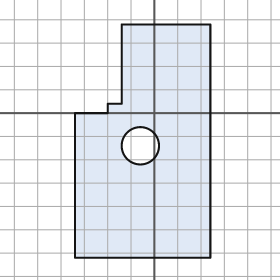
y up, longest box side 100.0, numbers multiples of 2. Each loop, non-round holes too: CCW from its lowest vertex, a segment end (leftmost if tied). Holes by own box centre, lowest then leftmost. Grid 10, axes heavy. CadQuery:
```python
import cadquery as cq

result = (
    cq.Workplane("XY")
    .moveTo(-34.0, -62.0)
    .lineTo(24.0, -62.0)
    .lineTo(24.0, 38.0)
    .lineTo(-14.0, 38.0)
    .lineTo(-14.0, 4.0)
    .lineTo(-20.0, 4.0)
    .lineTo(-20.0, 0.0)
    .lineTo(-34.0, 0.0)
    .close()
    .moveTo(-6.0, -14.0)
    .circle(8.0)
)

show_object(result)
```